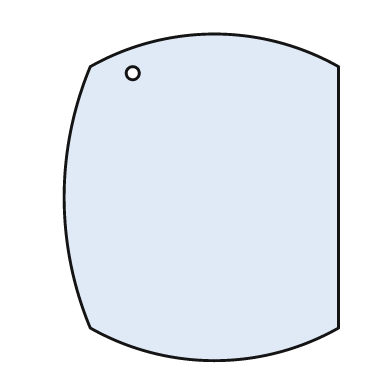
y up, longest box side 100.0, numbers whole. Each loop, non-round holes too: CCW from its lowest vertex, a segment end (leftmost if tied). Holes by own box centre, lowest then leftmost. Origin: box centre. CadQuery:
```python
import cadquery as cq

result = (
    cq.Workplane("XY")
    .moveTo(-34.0, -40.0)
    .threePointArc((4.0, -50.0), (42.0, -40.0))
    .lineTo(42.0, 40.0)
    .threePointArc((4.0, 50.0), (-34.0, 40.0))
    .threePointArc((-42.0, 0.0), (-34.0, -40.0))
    .close()
    .moveTo(-21.0, 38.0)
    .circle(2.0)
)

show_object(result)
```